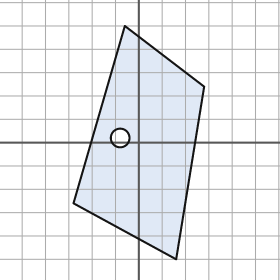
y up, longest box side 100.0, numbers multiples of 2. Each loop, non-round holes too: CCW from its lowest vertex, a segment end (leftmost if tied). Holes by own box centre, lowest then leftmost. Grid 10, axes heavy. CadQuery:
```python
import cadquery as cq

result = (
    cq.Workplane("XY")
    .moveTo(16.0, -50.0)
    .lineTo(28.0, 24.0)
    .lineTo(-6.0, 50.0)
    .lineTo(-28.0, -26.0)
    .close()
    .moveTo(-8.0, 2.0)
    .circle(4.0)
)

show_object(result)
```